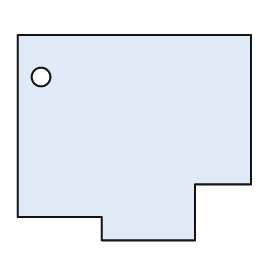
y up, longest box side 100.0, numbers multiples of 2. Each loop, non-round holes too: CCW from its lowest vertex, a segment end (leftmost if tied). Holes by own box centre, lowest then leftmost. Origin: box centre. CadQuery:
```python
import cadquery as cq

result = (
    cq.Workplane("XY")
    .moveTo(-14.0, -44.0)
    .lineTo(26.0, -44.0)
    .lineTo(26.0, -20.0)
    .lineTo(50.0, -20.0)
    .lineTo(50.0, 44.0)
    .lineTo(-50.0, 44.0)
    .lineTo(-50.0, -34.0)
    .lineTo(-14.0, -34.0)
    .close()
    .moveTo(-40.0, 26.0)
    .circle(4.0)
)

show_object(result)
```